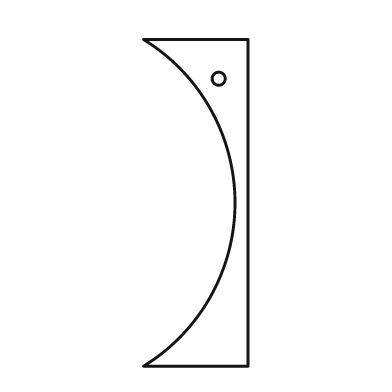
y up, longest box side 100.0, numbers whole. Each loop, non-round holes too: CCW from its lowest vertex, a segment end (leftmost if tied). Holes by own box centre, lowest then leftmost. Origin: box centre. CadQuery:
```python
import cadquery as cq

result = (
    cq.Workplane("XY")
    .moveTo(-16.0, -50.0)
    .lineTo(16.0, -50.0)
    .lineTo(16.0, 50.0)
    .lineTo(-16.0, 50.0)
    .threePointArc((12.0, 0.0), (-16.0, -50.0))
    .close()
    .moveTo(7.0, 38.0)
    .circle(2.0)
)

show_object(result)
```